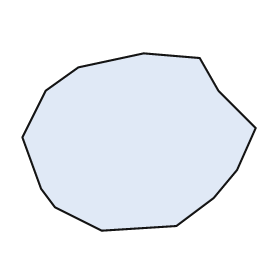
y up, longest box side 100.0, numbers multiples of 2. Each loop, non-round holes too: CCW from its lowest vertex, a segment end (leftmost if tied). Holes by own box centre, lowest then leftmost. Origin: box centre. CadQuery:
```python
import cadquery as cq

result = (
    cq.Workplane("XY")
    .moveTo(-16.0, -38.0)
    .lineTo(16.0, -36.0)
    .lineTo(32.0, -24.0)
    .lineTo(42.0, -12.0)
    .lineTo(50.0, 6.0)
    .lineTo(34.0, 22.0)
    .lineTo(26.0, 36.0)
    .lineTo(2.0, 38.0)
    .lineTo(-26.0, 32.0)
    .lineTo(-40.0, 22.0)
    .lineTo(-50.0, 2.0)
    .lineTo(-42.0, -20.0)
    .lineTo(-36.0, -28.0)
    .close()
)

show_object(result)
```